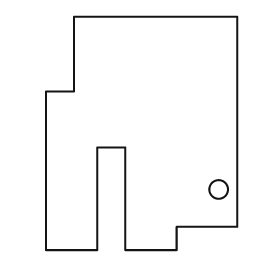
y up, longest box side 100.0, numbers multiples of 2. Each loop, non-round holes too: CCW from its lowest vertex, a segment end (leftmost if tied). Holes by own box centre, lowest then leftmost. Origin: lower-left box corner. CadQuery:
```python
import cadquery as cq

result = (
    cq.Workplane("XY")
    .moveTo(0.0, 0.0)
    .lineTo(22.0, 0.0)
    .lineTo(22.0, 44.0)
    .lineTo(34.0, 44.0)
    .lineTo(34.0, 0.0)
    .lineTo(56.0, 0.0)
    .lineTo(56.0, 10.0)
    .lineTo(82.0, 10.0)
    .lineTo(82.0, 100.0)
    .lineTo(12.0, 100.0)
    .lineTo(12.0, 68.0)
    .lineTo(0.0, 68.0)
    .close()
    .moveTo(74.0, 26.0)
    .circle(4.0)
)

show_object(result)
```